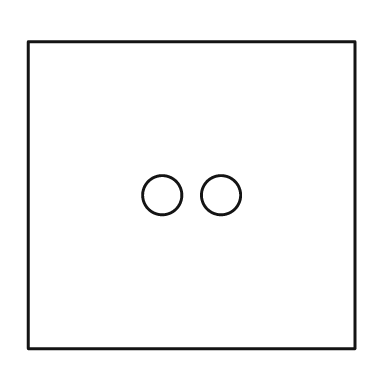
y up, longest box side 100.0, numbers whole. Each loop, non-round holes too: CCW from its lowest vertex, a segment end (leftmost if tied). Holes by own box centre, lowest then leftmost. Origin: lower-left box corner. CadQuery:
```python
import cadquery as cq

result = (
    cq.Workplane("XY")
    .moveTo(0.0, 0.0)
    .lineTo(100.0, 0.0)
    .lineTo(100.0, 94.0)
    .lineTo(0.0, 94.0)
    .close()
    .moveTo(41.0, 47.0)
    .circle(6.0)
    .moveTo(59.0, 47.0)
    .circle(6.0)
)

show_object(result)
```